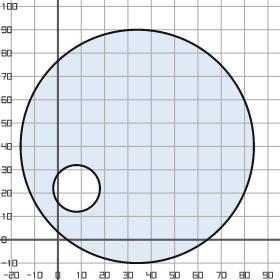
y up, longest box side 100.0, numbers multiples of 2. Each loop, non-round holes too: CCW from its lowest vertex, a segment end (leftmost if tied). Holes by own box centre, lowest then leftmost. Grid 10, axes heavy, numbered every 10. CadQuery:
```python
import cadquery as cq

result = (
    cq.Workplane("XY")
    .moveTo(34.0, 40.0)
    .circle(50.0)
    .moveTo(8.0, 22.0)
    .circle(10.0)
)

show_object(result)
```